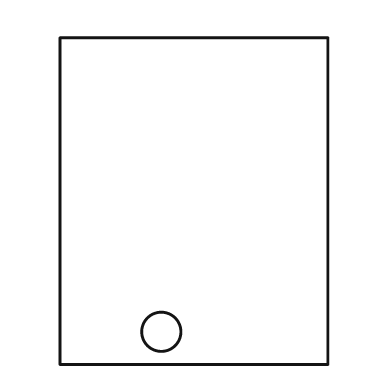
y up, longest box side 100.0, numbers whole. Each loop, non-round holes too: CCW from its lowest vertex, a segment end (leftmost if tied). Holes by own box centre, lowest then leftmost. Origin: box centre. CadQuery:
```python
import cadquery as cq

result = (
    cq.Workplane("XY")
    .moveTo(-41.0, -50.0)
    .lineTo(41.0, -50.0)
    .lineTo(41.0, 50.0)
    .lineTo(-41.0, 50.0)
    .close()
    .moveTo(-10.0, -40.0)
    .circle(6.0)
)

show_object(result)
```